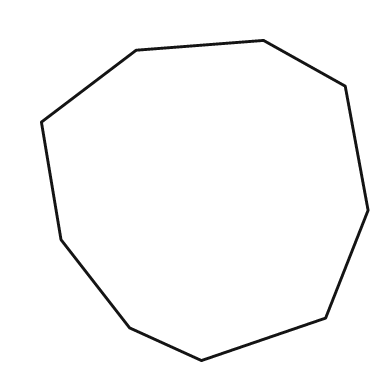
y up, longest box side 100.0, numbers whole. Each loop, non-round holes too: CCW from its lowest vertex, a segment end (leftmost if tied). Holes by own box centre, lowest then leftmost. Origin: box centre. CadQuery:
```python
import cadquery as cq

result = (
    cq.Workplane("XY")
    .moveTo(-1.0, -49.0)
    .lineTo(37.0, -36.0)
    .lineTo(50.0, -3.0)
    .lineTo(43.0, 35.0)
    .lineTo(18.0, 49.0)
    .lineTo(-21.0, 46.0)
    .lineTo(-50.0, 24.0)
    .lineTo(-44.0, -12.0)
    .lineTo(-23.0, -39.0)
    .close()
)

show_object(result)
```